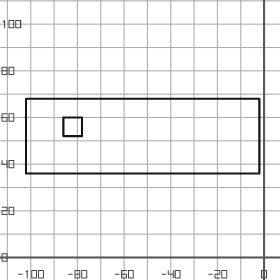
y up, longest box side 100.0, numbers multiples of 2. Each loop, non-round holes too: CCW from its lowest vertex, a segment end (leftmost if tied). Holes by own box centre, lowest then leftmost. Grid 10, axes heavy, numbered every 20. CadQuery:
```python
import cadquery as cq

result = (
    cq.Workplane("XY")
    .moveTo(-102.0, 36.0)
    .lineTo(-2.0, 36.0)
    .lineTo(-2.0, 68.0)
    .lineTo(-102.0, 68.0)
    .close()
    .moveTo(-86.0, 52.0)
    .lineTo(-78.0, 52.0)
    .lineTo(-78.0, 60.0)
    .lineTo(-86.0, 60.0)
    .close()
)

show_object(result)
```